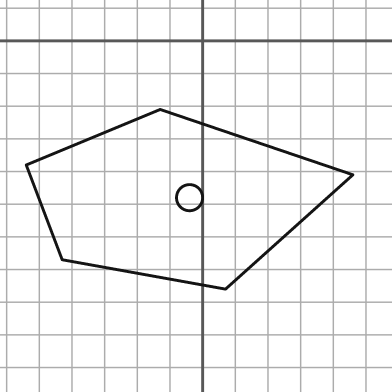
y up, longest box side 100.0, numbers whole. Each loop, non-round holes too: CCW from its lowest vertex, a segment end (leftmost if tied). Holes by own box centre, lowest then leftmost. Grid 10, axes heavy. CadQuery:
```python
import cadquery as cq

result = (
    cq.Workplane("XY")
    .moveTo(7.0, -76.0)
    .lineTo(46.0, -41.0)
    .lineTo(-13.0, -21.0)
    .lineTo(-54.0, -38.0)
    .lineTo(-43.0, -67.0)
    .close()
    .moveTo(-4.0, -48.0)
    .circle(4.0)
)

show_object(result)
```